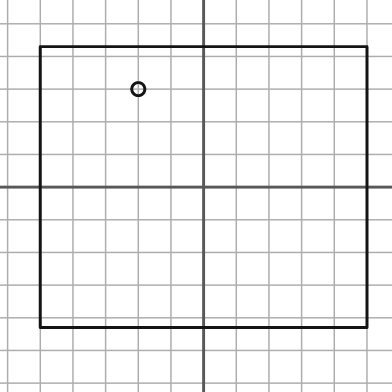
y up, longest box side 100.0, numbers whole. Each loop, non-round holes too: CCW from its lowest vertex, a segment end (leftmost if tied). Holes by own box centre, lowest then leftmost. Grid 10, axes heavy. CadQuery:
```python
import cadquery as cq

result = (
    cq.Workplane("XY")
    .moveTo(-50.0, -43.0)
    .lineTo(50.0, -43.0)
    .lineTo(50.0, 43.0)
    .lineTo(-50.0, 43.0)
    .close()
    .moveTo(-20.0, 30.0)
    .circle(2.0)
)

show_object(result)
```